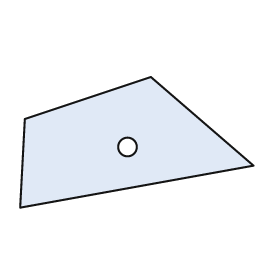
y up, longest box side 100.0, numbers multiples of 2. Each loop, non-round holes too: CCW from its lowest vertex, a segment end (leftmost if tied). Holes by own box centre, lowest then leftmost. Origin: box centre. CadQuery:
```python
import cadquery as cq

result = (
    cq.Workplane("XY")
    .moveTo(-50.0, -28.0)
    .lineTo(50.0, -10.0)
    .lineTo(6.0, 28.0)
    .lineTo(-48.0, 10.0)
    .close()
    .moveTo(-4.0, -2.0)
    .circle(4.0)
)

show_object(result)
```